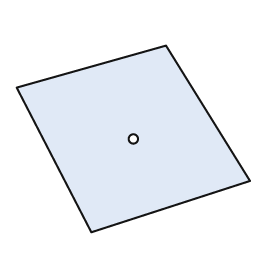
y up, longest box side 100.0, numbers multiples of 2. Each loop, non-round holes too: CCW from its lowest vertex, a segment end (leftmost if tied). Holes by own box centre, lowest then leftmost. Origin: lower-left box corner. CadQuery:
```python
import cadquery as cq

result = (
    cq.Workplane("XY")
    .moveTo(32.0, 0.0)
    .lineTo(100.0, 22.0)
    .lineTo(64.0, 80.0)
    .lineTo(0.0, 62.0)
    .close()
    .moveTo(50.0, 40.0)
    .circle(2.0)
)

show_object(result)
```